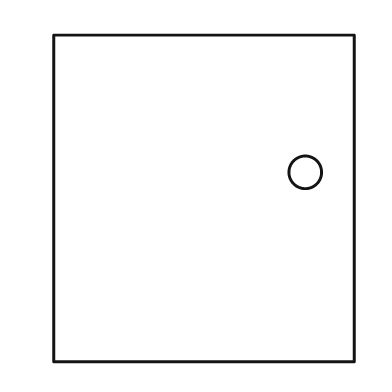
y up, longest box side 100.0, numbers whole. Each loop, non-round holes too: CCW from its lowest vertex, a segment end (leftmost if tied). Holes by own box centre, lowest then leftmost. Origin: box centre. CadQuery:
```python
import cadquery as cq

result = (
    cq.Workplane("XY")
    .moveTo(-46.0, -50.0)
    .lineTo(46.0, -50.0)
    .lineTo(46.0, 50.0)
    .lineTo(-46.0, 50.0)
    .close()
    .moveTo(31.0, 8.0)
    .circle(5.0)
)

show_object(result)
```